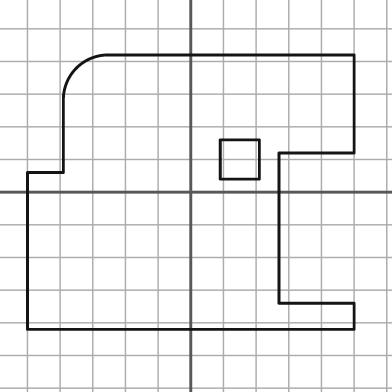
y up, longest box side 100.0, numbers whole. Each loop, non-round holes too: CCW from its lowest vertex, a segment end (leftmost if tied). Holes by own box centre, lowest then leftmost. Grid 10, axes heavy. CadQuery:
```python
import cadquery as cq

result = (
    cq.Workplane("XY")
    .moveTo(-50.0, -42.0)
    .lineTo(50.0, -42.0)
    .lineTo(50.0, -34.0)
    .lineTo(27.0, -34.0)
    .lineTo(27.0, 12.0)
    .lineTo(50.0, 12.0)
    .lineTo(50.0, 42.0)
    .lineTo(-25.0, 42.0)
    .threePointArc((-35.0, 38.0), (-39.0, 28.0))
    .lineTo(-39.0, 6.0)
    .lineTo(-50.0, 6.0)
    .close()
    .moveTo(9.0, 4.0)
    .lineTo(21.0, 4.0)
    .lineTo(21.0, 16.0)
    .lineTo(9.0, 16.0)
    .close()
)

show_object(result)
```